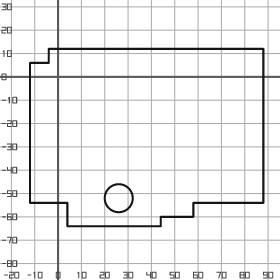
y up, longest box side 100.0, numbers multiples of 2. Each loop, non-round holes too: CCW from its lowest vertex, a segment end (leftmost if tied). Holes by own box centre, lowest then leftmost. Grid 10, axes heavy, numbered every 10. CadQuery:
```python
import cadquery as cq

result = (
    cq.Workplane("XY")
    .moveTo(4.0, -64.0)
    .lineTo(44.0, -64.0)
    .lineTo(44.0, -60.0)
    .lineTo(58.0, -60.0)
    .lineTo(58.0, -54.0)
    .lineTo(88.0, -54.0)
    .lineTo(88.0, 12.0)
    .lineTo(-4.0, 12.0)
    .lineTo(-4.0, 6.0)
    .lineTo(-12.0, 6.0)
    .lineTo(-12.0, -54.0)
    .lineTo(4.0, -54.0)
    .close()
    .moveTo(26.0, -52.0)
    .circle(6.0)
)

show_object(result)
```